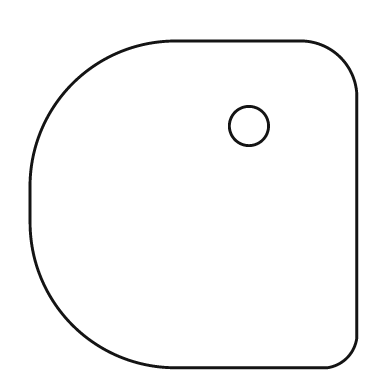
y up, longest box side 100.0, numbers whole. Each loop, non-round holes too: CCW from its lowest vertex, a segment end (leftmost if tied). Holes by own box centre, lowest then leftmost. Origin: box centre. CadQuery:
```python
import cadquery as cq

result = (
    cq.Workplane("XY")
    .moveTo(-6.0, -50.0)
    .lineTo(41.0, -50.0)
    .threePointArc((47.0, -47.0), (50.0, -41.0))
    .lineTo(50.0, 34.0)
    .threePointArc((45.0, 45.0), (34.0, 50.0))
    .lineTo(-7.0, 50.0)
    .threePointArc((-37.0, 37.0), (-50.0, 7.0))
    .lineTo(-50.0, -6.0)
    .threePointArc((-37.0, -37.0), (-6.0, -50.0))
    .close()
    .moveTo(17.0, 24.0)
    .circle(6.0)
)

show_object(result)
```